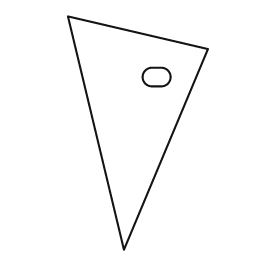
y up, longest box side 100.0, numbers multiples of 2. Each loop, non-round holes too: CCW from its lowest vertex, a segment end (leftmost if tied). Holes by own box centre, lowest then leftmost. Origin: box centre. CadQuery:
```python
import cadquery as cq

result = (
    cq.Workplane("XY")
    .moveTo(-6.0, -50.0)
    .lineTo(30.0, 36.0)
    .lineTo(-30.0, 50.0)
    .close()
    .moveTo(6.0, 20.0)
    .lineTo(10.0, 20.0)
    .threePointArc((14.0, 24.0), (10.0, 28.0))
    .lineTo(6.0, 28.0)
    .threePointArc((2.0, 24.0), (6.0, 20.0))
    .close()
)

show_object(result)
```